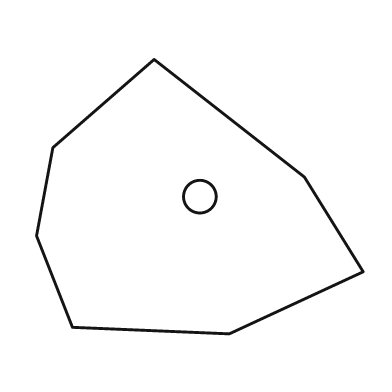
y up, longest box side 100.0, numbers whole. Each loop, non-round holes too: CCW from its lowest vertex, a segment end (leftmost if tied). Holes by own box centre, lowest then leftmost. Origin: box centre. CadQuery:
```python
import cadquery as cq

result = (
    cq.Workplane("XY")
    .moveTo(9.0, -42.0)
    .lineTo(50.0, -23.0)
    .lineTo(32.0, 6.0)
    .lineTo(-14.0, 42.0)
    .lineTo(-45.0, 15.0)
    .lineTo(-50.0, -12.0)
    .lineTo(-39.0, -40.0)
    .close()
    .moveTo(0.0, 0.0)
    .circle(5.0)
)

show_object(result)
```